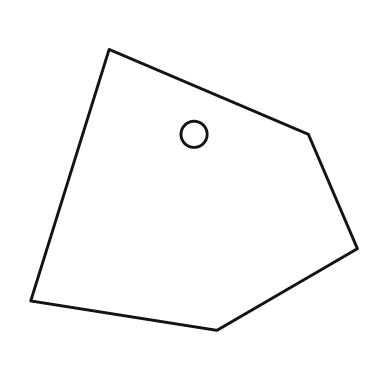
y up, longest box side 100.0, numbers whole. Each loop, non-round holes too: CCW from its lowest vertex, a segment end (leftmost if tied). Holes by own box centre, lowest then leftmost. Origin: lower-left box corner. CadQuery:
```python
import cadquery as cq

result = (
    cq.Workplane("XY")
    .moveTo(57.0, 0.0)
    .lineTo(100.0, 25.0)
    .lineTo(85.0, 60.0)
    .lineTo(24.0, 86.0)
    .lineTo(0.0, 9.0)
    .close()
    .moveTo(50.0, 60.0)
    .circle(4.0)
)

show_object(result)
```